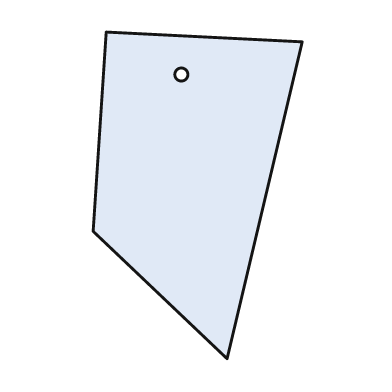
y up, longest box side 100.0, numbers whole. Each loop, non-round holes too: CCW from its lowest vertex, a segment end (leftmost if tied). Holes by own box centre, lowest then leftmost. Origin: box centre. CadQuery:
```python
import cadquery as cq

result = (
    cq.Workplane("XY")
    .moveTo(9.0, -50.0)
    .lineTo(32.0, 47.0)
    .lineTo(-28.0, 50.0)
    .lineTo(-32.0, -11.0)
    .close()
    .moveTo(-5.0, 37.0)
    .circle(2.0)
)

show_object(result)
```